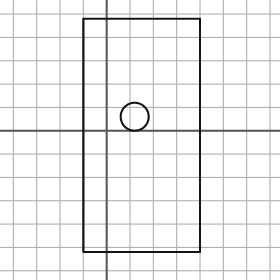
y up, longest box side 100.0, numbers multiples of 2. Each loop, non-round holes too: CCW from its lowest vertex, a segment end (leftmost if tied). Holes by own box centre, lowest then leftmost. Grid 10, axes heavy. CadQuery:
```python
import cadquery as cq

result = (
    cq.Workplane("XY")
    .moveTo(-10.0, -52.0)
    .lineTo(40.0, -52.0)
    .lineTo(40.0, 48.0)
    .lineTo(-10.0, 48.0)
    .close()
    .moveTo(12.0, 6.0)
    .circle(6.0)
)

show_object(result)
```